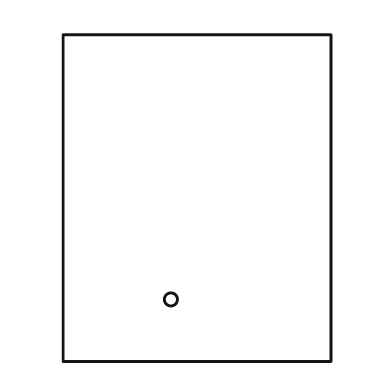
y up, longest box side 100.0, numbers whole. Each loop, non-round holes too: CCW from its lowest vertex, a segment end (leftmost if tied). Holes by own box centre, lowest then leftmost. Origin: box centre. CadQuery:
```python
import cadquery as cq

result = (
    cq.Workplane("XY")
    .moveTo(-41.0, -50.0)
    .lineTo(41.0, -50.0)
    .lineTo(41.0, 50.0)
    .lineTo(-41.0, 50.0)
    .close()
    .moveTo(-8.0, -31.0)
    .circle(2.0)
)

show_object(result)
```